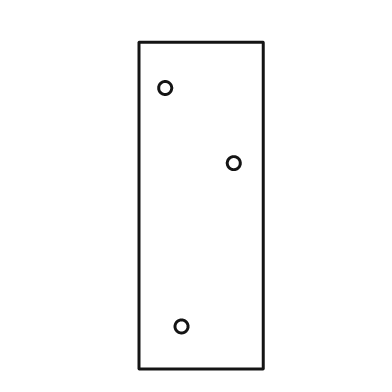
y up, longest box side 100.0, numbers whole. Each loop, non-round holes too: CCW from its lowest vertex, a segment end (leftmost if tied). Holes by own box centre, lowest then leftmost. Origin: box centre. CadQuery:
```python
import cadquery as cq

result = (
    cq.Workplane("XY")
    .moveTo(-19.0, -50.0)
    .lineTo(19.0, -50.0)
    .lineTo(19.0, 50.0)
    .lineTo(-19.0, 50.0)
    .close()
    .moveTo(-6.0, -37.0)
    .circle(2.0)
    .moveTo(10.0, 13.0)
    .circle(2.0)
    .moveTo(-11.0, 36.0)
    .circle(2.0)
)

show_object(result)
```